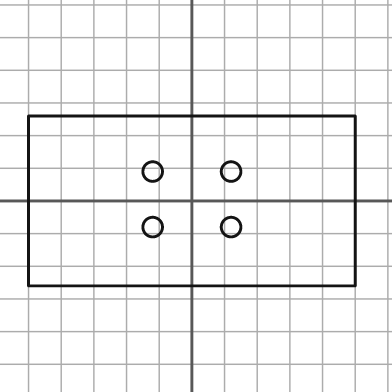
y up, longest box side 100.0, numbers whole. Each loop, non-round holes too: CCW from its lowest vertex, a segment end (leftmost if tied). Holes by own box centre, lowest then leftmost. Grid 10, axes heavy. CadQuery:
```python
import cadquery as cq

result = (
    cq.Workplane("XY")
    .moveTo(-50.0, -26.0)
    .lineTo(50.0, -26.0)
    .lineTo(50.0, 26.0)
    .lineTo(-50.0, 26.0)
    .close()
    .moveTo(-12.0, -8.0)
    .circle(3.0)
    .moveTo(12.0, -8.0)
    .circle(3.0)
    .moveTo(-12.0, 9.0)
    .circle(3.0)
    .moveTo(12.0, 9.0)
    .circle(3.0)
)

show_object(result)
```